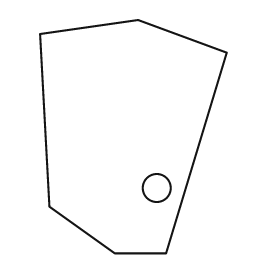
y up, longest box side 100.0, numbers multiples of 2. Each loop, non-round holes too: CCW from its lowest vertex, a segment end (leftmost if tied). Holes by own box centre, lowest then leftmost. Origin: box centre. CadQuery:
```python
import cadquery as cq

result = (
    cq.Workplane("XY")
    .moveTo(-8.0, -50.0)
    .lineTo(14.0, -50.0)
    .lineTo(40.0, 36.0)
    .lineTo(2.0, 50.0)
    .lineTo(-40.0, 44.0)
    .lineTo(-36.0, -30.0)
    .close()
    .moveTo(10.0, -22.0)
    .circle(6.0)
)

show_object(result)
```